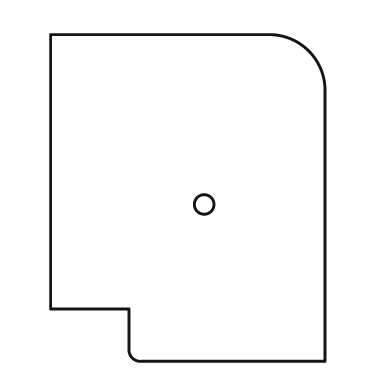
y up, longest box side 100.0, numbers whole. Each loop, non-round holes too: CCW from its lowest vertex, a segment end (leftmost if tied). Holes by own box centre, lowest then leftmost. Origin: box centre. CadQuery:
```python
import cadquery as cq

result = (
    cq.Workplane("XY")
    .moveTo(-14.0, -50.0)
    .lineTo(42.0, -50.0)
    .lineTo(42.0, 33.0)
    .threePointArc((37.0, 45.0), (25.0, 50.0))
    .lineTo(-42.0, 50.0)
    .lineTo(-42.0, -34.0)
    .lineTo(-18.0, -34.0)
    .lineTo(-18.0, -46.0)
    .threePointArc((-17.0, -49.0), (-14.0, -50.0))
    .close()
    .moveTo(5.0, -2.0)
    .circle(3.0)
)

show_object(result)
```